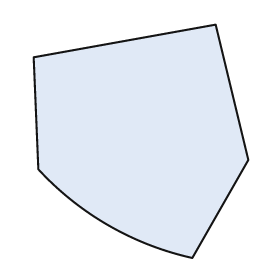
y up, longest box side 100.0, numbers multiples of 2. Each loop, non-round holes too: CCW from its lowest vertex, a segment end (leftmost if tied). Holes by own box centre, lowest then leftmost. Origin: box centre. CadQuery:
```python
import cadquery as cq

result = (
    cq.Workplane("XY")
    .moveTo(22.0, -50.0)
    .lineTo(46.0, -8.0)
    .lineTo(32.0, 50.0)
    .lineTo(-46.0, 36.0)
    .lineTo(-44.0, -12.0)
    .threePointArc((-14.0, -36.0), (22.0, -50.0))
    .close()
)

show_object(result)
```